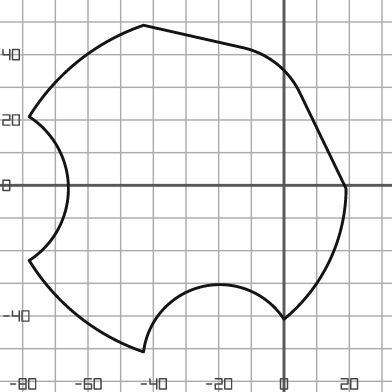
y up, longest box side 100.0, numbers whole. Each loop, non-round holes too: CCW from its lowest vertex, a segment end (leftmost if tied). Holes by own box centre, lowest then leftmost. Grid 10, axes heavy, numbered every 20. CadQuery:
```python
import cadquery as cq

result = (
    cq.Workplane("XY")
    .moveTo(-43.0, -51.0)
    .threePointArc((-25.0, -31.0), (0.0, -41.0))
    .threePointArc((14.0, -23.0), (19.0, -1.0))
    .lineTo(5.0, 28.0)
    .threePointArc((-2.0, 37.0), (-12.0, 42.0))
    .lineTo(-43.0, 49.0)
    .threePointArc((-63.0, 38.0), (-78.0, 21.0))
    .threePointArc((-66.0, -1.0), (-78.0, -23.0))
    .threePointArc((-63.0, -40.0), (-43.0, -51.0))
    .close()
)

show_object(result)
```